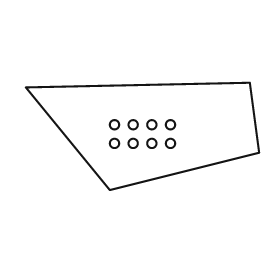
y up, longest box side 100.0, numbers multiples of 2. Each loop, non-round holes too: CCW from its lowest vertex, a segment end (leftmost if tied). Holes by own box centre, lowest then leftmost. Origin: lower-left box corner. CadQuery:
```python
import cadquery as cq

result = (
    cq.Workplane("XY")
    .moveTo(36.0, 0.0)
    .lineTo(100.0, 16.0)
    .lineTo(96.0, 46.0)
    .lineTo(0.0, 44.0)
    .close()
    .moveTo(38.0, 20.0)
    .circle(2.0)
    .moveTo(46.0, 20.0)
    .circle(2.0)
    .moveTo(54.0, 20.0)
    .circle(2.0)
    .moveTo(62.0, 20.0)
    .circle(2.0)
    .moveTo(38.0, 28.0)
    .circle(2.0)
    .moveTo(46.0, 28.0)
    .circle(2.0)
    .moveTo(54.0, 28.0)
    .circle(2.0)
    .moveTo(62.0, 28.0)
    .circle(2.0)
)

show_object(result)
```